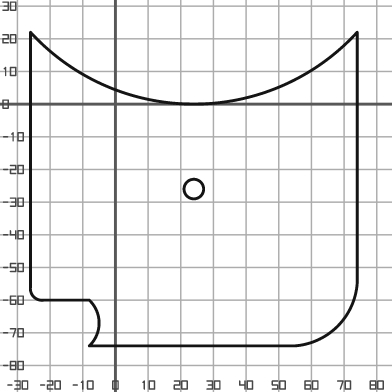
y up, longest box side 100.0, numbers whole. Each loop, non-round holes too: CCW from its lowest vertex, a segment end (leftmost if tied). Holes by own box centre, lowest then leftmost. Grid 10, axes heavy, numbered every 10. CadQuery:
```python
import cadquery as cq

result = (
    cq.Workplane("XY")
    .moveTo(-8.0, -74.0)
    .lineTo(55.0, -74.0)
    .threePointArc((68.0, -68.0), (74.0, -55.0))
    .lineTo(74.0, 22.0)
    .threePointArc((24.0, 0.0), (-26.0, 22.0))
    .lineTo(-26.0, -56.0)
    .threePointArc((-25.0, -59.0), (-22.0, -60.0))
    .lineTo(-8.0, -60.0)
    .threePointArc((-5.0, -67.0), (-8.0, -74.0))
    .close()
    .moveTo(24.0, -26.0)
    .circle(3.0)
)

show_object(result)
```